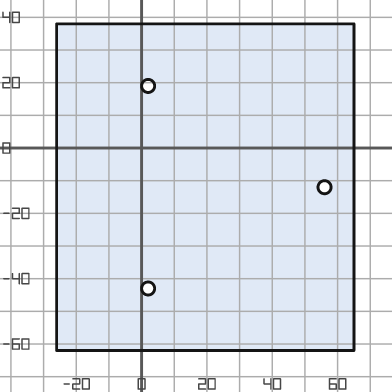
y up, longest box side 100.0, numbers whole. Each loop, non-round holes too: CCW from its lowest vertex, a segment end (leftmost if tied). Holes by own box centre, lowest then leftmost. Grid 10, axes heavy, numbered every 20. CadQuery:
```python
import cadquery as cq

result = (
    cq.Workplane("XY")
    .moveTo(-26.0, -62.0)
    .lineTo(65.0, -62.0)
    .lineTo(65.0, 38.0)
    .lineTo(-26.0, 38.0)
    .close()
    .moveTo(2.0, -43.0)
    .circle(2.0)
    .moveTo(56.0, -12.0)
    .circle(2.0)
    .moveTo(2.0, 19.0)
    .circle(2.0)
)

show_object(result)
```